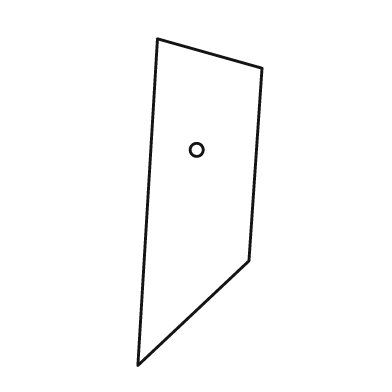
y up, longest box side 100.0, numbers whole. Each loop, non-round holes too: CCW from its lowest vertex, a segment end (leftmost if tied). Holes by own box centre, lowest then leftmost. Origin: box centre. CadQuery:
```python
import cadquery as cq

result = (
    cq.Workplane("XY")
    .moveTo(-19.0, -50.0)
    .lineTo(15.0, -18.0)
    .lineTo(19.0, 41.0)
    .lineTo(-13.0, 50.0)
    .close()
    .moveTo(-1.0, 16.0)
    .circle(2.0)
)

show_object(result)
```